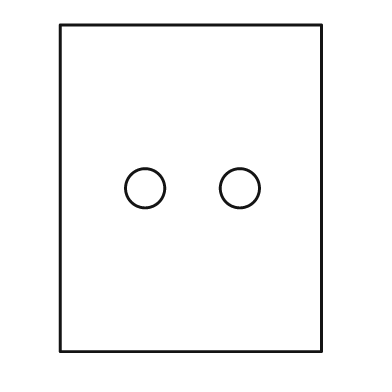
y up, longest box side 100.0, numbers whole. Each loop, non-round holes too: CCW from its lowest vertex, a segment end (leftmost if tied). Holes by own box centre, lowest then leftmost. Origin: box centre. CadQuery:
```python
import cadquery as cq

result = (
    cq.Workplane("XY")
    .moveTo(-40.0, -50.0)
    .lineTo(40.0, -50.0)
    .lineTo(40.0, 50.0)
    .lineTo(-40.0, 50.0)
    .close()
    .moveTo(-14.0, 0.0)
    .circle(6.0)
    .moveTo(15.0, 0.0)
    .circle(6.0)
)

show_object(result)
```